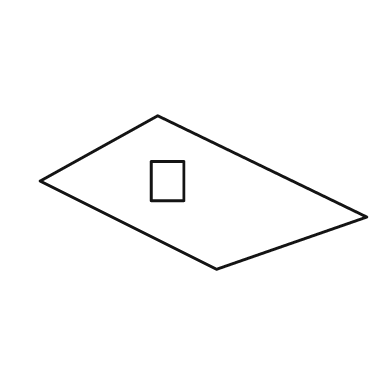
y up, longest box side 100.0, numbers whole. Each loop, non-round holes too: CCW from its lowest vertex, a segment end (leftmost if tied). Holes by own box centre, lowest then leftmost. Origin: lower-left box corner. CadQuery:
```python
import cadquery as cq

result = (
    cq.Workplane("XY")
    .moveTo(54.0, 0.0)
    .lineTo(100.0, 16.0)
    .lineTo(36.0, 47.0)
    .lineTo(0.0, 27.0)
    .close()
    .moveTo(34.0, 21.0)
    .lineTo(44.0, 21.0)
    .lineTo(44.0, 33.0)
    .lineTo(34.0, 33.0)
    .close()
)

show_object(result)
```